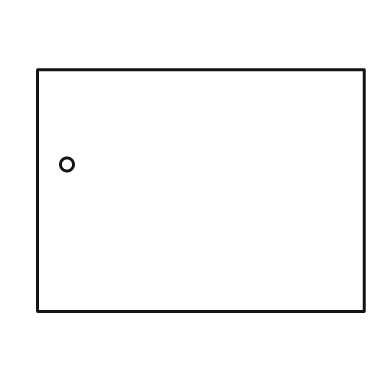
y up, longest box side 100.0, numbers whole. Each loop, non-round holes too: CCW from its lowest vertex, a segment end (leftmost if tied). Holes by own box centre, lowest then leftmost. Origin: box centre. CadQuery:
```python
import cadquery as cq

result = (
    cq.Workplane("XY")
    .moveTo(-50.0, -37.0)
    .lineTo(50.0, -37.0)
    .lineTo(50.0, 37.0)
    .lineTo(-50.0, 37.0)
    .close()
    .moveTo(-41.0, 8.0)
    .circle(2.0)
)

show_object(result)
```